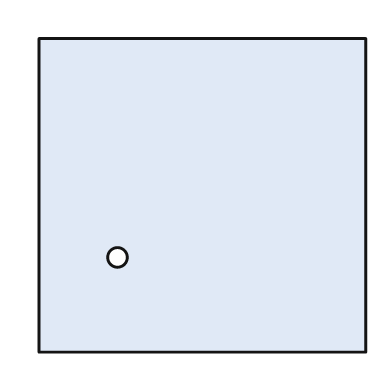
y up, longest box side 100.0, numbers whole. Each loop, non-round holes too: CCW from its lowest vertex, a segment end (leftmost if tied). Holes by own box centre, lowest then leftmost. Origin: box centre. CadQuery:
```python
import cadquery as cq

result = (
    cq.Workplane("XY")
    .moveTo(-50.0, -48.0)
    .lineTo(50.0, -48.0)
    .lineTo(50.0, 48.0)
    .lineTo(-50.0, 48.0)
    .close()
    .moveTo(-26.0, -19.0)
    .circle(3.0)
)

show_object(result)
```